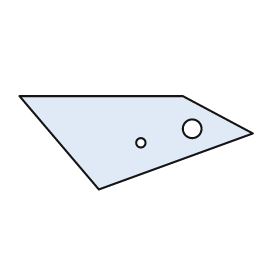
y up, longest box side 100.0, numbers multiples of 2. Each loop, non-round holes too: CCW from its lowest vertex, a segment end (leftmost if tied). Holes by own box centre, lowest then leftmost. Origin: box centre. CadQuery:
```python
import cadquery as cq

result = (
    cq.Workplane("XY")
    .moveTo(-16.0, -20.0)
    .lineTo(50.0, 4.0)
    .lineTo(20.0, 20.0)
    .lineTo(-50.0, 20.0)
    .close()
    .moveTo(2.0, 0.0)
    .circle(2.0)
    .moveTo(24.0, 6.0)
    .circle(4.0)
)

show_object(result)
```